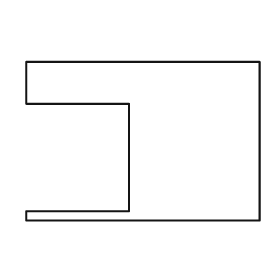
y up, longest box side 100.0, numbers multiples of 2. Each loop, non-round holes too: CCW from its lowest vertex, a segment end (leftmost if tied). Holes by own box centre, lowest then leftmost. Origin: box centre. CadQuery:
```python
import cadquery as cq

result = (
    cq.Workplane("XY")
    .moveTo(-50.0, -34.0)
    .lineTo(50.0, -34.0)
    .lineTo(50.0, 34.0)
    .lineTo(-50.0, 34.0)
    .lineTo(-50.0, 16.0)
    .lineTo(-6.0, 16.0)
    .lineTo(-6.0, -30.0)
    .lineTo(-50.0, -30.0)
    .close()
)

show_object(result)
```